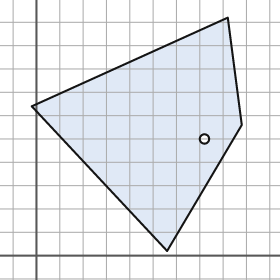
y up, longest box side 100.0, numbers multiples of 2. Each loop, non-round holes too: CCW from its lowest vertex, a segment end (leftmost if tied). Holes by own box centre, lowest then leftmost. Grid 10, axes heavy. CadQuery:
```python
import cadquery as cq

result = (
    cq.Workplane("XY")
    .moveTo(56.0, 2.0)
    .lineTo(88.0, 56.0)
    .lineTo(82.0, 102.0)
    .lineTo(-2.0, 64.0)
    .close()
    .moveTo(72.0, 50.0)
    .circle(2.0)
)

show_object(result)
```